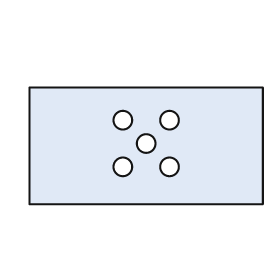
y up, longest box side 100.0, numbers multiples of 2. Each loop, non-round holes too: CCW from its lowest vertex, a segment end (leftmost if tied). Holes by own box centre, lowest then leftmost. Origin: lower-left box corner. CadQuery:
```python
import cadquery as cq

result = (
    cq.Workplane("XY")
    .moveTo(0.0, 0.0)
    .lineTo(100.0, 0.0)
    .lineTo(100.0, 50.0)
    .lineTo(0.0, 50.0)
    .close()
    .moveTo(40.0, 16.0)
    .circle(4.0)
    .moveTo(60.0, 16.0)
    .circle(4.0)
    .moveTo(50.0, 26.0)
    .circle(4.0)
    .moveTo(40.0, 36.0)
    .circle(4.0)
    .moveTo(60.0, 36.0)
    .circle(4.0)
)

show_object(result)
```